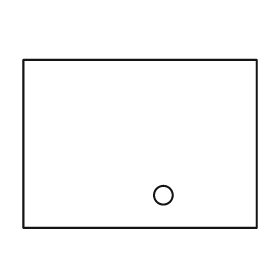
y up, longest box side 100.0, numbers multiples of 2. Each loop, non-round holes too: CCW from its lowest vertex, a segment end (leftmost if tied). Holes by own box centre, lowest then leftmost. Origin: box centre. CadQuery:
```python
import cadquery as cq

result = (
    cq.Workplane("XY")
    .moveTo(-50.0, -36.0)
    .lineTo(50.0, -36.0)
    .lineTo(50.0, 36.0)
    .lineTo(-50.0, 36.0)
    .close()
    .moveTo(10.0, -22.0)
    .circle(4.0)
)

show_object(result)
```